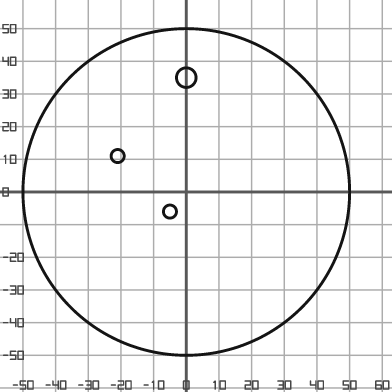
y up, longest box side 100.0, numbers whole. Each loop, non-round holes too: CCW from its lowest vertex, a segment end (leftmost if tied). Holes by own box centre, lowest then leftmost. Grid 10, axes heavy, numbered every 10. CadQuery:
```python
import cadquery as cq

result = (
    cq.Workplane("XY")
    .moveTo(0.0, 0.0)
    .circle(50.0)
    .moveTo(-5.0, -6.0)
    .circle(2.0)
    .moveTo(-21.0, 11.0)
    .circle(2.0)
    .moveTo(0.0, 35.0)
    .circle(3.0)
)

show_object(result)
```